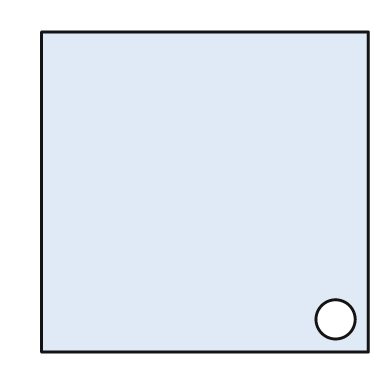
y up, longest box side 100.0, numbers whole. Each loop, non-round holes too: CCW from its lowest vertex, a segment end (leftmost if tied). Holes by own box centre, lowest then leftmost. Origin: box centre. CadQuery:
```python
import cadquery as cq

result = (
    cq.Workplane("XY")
    .moveTo(-50.0, -49.0)
    .lineTo(50.0, -49.0)
    .lineTo(50.0, 49.0)
    .lineTo(-50.0, 49.0)
    .close()
    .moveTo(40.0, -39.0)
    .circle(6.0)
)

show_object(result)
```